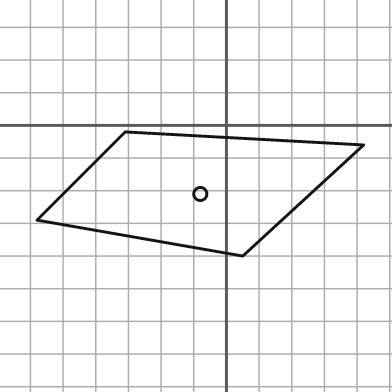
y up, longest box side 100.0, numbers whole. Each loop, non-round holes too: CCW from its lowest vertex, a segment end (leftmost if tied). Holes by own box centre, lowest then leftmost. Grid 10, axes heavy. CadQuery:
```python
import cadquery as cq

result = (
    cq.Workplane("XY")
    .moveTo(5.0, -40.0)
    .lineTo(42.0, -6.0)
    .lineTo(-31.0, -2.0)
    .lineTo(-58.0, -29.0)
    .close()
    .moveTo(-8.0, -21.0)
    .circle(2.0)
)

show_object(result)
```